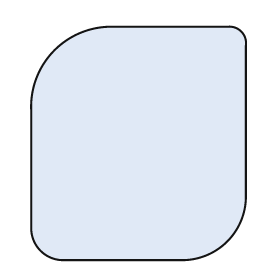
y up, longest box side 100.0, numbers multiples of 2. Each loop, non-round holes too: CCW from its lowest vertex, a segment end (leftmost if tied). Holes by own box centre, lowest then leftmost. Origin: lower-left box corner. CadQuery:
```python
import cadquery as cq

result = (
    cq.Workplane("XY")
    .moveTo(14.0, 0.0)
    .lineTo(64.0, 0.0)
    .threePointArc((84.0, 8.0), (92.0, 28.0))
    .lineTo(92.0, 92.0)
    .threePointArc((90.0, 98.0), (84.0, 100.0))
    .lineTo(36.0, 100.0)
    .threePointArc((10.0, 90.0), (0.0, 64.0))
    .lineTo(0.0, 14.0)
    .threePointArc((4.0, 4.0), (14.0, 0.0))
    .close()
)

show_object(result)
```